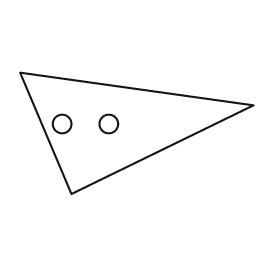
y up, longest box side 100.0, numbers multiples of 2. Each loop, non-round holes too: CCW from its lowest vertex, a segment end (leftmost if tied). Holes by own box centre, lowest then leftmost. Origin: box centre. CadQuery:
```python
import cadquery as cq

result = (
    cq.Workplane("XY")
    .moveTo(-28.0, -26.0)
    .lineTo(50.0, 12.0)
    .lineTo(-50.0, 26.0)
    .close()
    .moveTo(-32.0, 4.0)
    .circle(4.0)
    .moveTo(-12.0, 4.0)
    .circle(4.0)
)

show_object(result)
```